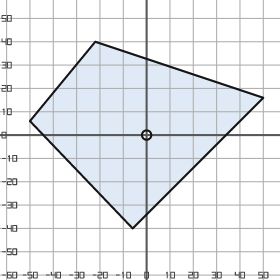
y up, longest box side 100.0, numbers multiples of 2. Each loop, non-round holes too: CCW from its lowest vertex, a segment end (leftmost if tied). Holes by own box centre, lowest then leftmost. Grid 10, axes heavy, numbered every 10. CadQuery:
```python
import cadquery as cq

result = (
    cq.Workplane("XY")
    .moveTo(-6.0, -40.0)
    .lineTo(50.0, 16.0)
    .lineTo(-22.0, 40.0)
    .lineTo(-50.0, 6.0)
    .close()
    .moveTo(0.0, 0.0)
    .circle(2.0)
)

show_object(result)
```